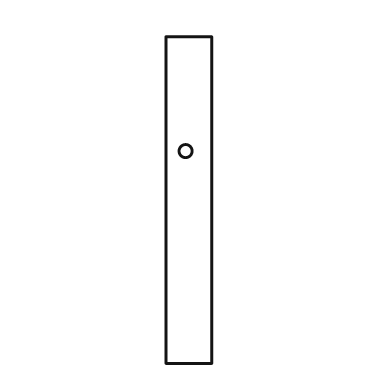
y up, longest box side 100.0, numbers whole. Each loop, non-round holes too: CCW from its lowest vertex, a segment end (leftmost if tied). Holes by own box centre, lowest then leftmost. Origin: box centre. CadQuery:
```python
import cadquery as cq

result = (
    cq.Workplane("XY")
    .moveTo(-7.0, -50.0)
    .lineTo(7.0, -50.0)
    .lineTo(7.0, 50.0)
    .lineTo(-7.0, 50.0)
    .close()
    .moveTo(-1.0, 15.0)
    .circle(2.0)
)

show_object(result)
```